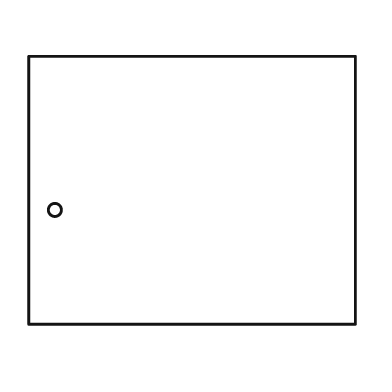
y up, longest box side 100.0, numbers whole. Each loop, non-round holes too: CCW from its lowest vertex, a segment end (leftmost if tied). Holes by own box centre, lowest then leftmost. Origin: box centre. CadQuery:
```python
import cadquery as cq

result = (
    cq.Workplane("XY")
    .moveTo(-50.0, -41.0)
    .lineTo(50.0, -41.0)
    .lineTo(50.0, 41.0)
    .lineTo(-50.0, 41.0)
    .close()
    .moveTo(-42.0, -6.0)
    .circle(2.0)
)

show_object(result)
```